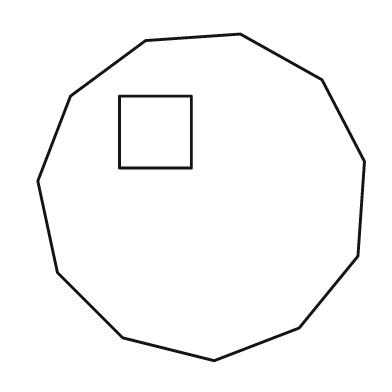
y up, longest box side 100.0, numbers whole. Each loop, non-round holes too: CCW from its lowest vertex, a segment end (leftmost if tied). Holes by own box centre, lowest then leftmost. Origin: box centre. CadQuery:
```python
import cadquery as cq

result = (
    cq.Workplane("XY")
    .moveTo(4.0, -50.0)
    .lineTo(30.0, -40.0)
    .lineTo(48.0, -18.0)
    .lineTo(50.0, 11.0)
    .lineTo(37.0, 36.0)
    .lineTo(12.0, 50.0)
    .lineTo(-17.0, 48.0)
    .lineTo(-40.0, 31.0)
    .lineTo(-50.0, 5.0)
    .lineTo(-44.0, -23.0)
    .lineTo(-24.0, -43.0)
    .close()
    .moveTo(-25.0, 9.0)
    .lineTo(-3.0, 9.0)
    .lineTo(-3.0, 31.0)
    .lineTo(-25.0, 31.0)
    .close()
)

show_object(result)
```